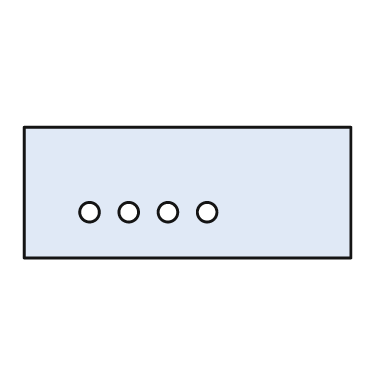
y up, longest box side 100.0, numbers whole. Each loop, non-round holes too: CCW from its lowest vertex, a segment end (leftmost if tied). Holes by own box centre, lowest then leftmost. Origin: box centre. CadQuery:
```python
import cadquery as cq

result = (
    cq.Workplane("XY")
    .moveTo(-50.0, -20.0)
    .lineTo(50.0, -20.0)
    .lineTo(50.0, 20.0)
    .lineTo(-50.0, 20.0)
    .close()
    .moveTo(-30.0, -6.0)
    .circle(3.0)
    .moveTo(-18.0, -6.0)
    .circle(3.0)
    .moveTo(-6.0, -6.0)
    .circle(3.0)
    .moveTo(6.0, -6.0)
    .circle(3.0)
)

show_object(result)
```